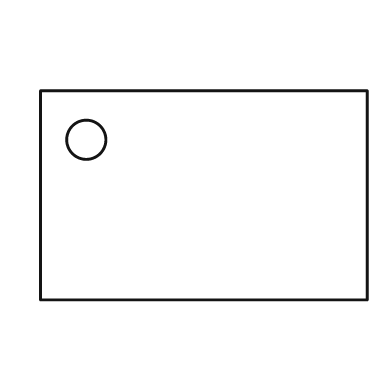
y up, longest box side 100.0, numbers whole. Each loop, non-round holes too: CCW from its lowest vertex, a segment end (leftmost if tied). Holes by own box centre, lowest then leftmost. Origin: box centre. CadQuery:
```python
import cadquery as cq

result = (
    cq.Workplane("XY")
    .moveTo(-50.0, -32.0)
    .lineTo(50.0, -32.0)
    .lineTo(50.0, 32.0)
    .lineTo(-50.0, 32.0)
    .close()
    .moveTo(-36.0, 17.0)
    .circle(6.0)
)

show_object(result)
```